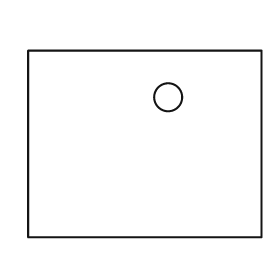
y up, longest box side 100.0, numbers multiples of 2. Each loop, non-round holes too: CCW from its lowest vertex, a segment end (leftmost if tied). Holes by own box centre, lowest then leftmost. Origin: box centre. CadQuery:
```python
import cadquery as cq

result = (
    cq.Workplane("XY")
    .moveTo(-50.0, -40.0)
    .lineTo(50.0, -40.0)
    .lineTo(50.0, 40.0)
    .lineTo(-50.0, 40.0)
    .close()
    .moveTo(10.0, 20.0)
    .circle(6.0)
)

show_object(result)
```